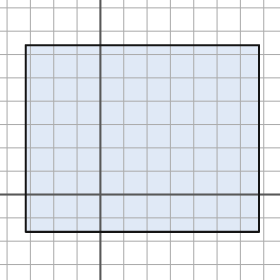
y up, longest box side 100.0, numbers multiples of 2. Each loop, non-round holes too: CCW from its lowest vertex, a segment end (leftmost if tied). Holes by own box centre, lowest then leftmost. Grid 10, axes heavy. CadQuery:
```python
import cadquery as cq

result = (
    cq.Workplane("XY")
    .moveTo(-32.0, -16.0)
    .lineTo(68.0, -16.0)
    .lineTo(68.0, 64.0)
    .lineTo(-32.0, 64.0)
    .close()
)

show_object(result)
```